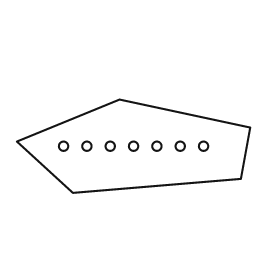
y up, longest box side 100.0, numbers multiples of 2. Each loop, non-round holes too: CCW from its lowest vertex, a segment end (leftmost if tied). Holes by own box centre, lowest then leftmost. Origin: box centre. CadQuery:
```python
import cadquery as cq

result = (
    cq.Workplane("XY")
    .moveTo(-26.0, -20.0)
    .lineTo(46.0, -14.0)
    .lineTo(50.0, 8.0)
    .lineTo(-6.0, 20.0)
    .lineTo(-50.0, 2.0)
    .close()
    .moveTo(-30.0, 0.0)
    .circle(2.0)
    .moveTo(-20.0, 0.0)
    .circle(2.0)
    .moveTo(-10.0, 0.0)
    .circle(2.0)
    .moveTo(0.0, 0.0)
    .circle(2.0)
    .moveTo(10.0, 0.0)
    .circle(2.0)
    .moveTo(20.0, 0.0)
    .circle(2.0)
    .moveTo(30.0, 0.0)
    .circle(2.0)
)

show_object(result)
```